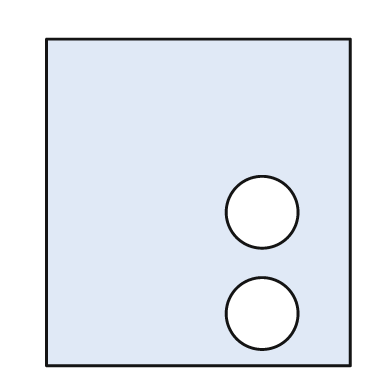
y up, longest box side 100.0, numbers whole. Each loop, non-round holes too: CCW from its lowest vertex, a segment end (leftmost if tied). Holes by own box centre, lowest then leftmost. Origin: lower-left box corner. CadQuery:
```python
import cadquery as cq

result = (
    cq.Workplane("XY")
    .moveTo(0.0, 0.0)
    .lineTo(93.0, 0.0)
    .lineTo(93.0, 100.0)
    .lineTo(0.0, 100.0)
    .close()
    .moveTo(66.0, 16.0)
    .circle(11.0)
    .moveTo(66.0, 47.0)
    .circle(11.0)
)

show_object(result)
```